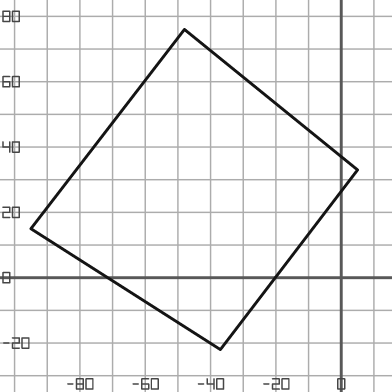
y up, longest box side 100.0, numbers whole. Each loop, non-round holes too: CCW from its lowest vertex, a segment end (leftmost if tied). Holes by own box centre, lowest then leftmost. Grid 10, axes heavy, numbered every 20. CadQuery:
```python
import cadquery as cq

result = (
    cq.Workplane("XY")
    .moveTo(-37.0, -22.0)
    .lineTo(5.0, 33.0)
    .lineTo(-48.0, 76.0)
    .lineTo(-95.0, 15.0)
    .close()
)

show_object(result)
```